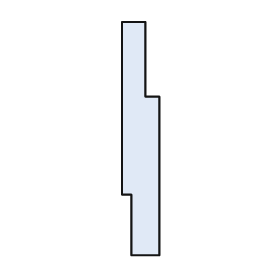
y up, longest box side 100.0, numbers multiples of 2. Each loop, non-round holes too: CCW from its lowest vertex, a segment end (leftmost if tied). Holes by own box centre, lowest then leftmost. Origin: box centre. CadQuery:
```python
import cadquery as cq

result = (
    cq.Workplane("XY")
    .moveTo(-4.0, -50.0)
    .lineTo(8.0, -50.0)
    .lineTo(8.0, 18.0)
    .lineTo(2.0, 18.0)
    .lineTo(2.0, 50.0)
    .lineTo(-8.0, 50.0)
    .lineTo(-8.0, -24.0)
    .lineTo(-4.0, -24.0)
    .close()
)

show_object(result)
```